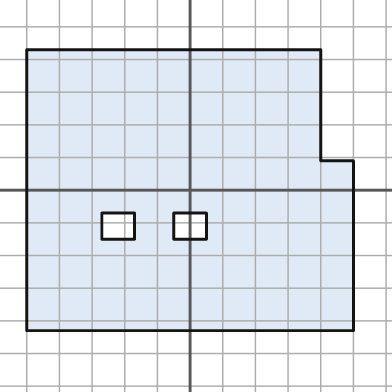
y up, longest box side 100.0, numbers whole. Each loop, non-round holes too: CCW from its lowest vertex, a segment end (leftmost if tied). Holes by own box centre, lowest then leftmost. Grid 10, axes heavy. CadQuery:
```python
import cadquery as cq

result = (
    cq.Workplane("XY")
    .moveTo(-50.0, -43.0)
    .lineTo(50.0, -43.0)
    .lineTo(50.0, 9.0)
    .lineTo(40.0, 9.0)
    .lineTo(40.0, 43.0)
    .lineTo(-50.0, 43.0)
    .close()
    .moveTo(-27.0, -15.0)
    .lineTo(-17.0, -15.0)
    .lineTo(-17.0, -7.0)
    .lineTo(-27.0, -7.0)
    .close()
    .moveTo(-5.0, -15.0)
    .lineTo(5.0, -15.0)
    .lineTo(5.0, -7.0)
    .lineTo(-5.0, -7.0)
    .close()
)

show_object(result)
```